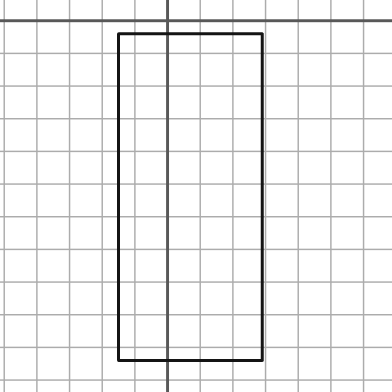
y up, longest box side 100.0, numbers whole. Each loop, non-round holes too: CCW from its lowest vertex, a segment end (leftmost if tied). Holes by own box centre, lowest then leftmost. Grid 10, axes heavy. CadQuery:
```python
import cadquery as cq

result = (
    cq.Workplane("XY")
    .moveTo(-15.0, -104.0)
    .lineTo(29.0, -104.0)
    .lineTo(29.0, -4.0)
    .lineTo(-15.0, -4.0)
    .close()
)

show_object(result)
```